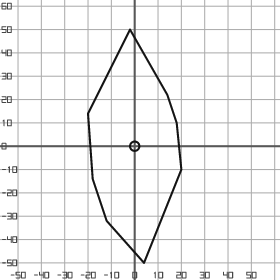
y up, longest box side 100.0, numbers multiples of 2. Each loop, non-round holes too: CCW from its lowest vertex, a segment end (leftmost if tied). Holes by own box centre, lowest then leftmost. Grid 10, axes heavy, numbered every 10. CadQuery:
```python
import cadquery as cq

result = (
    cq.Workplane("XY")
    .moveTo(4.0, -50.0)
    .lineTo(20.0, -10.0)
    .lineTo(18.0, 10.0)
    .lineTo(14.0, 22.0)
    .lineTo(-2.0, 50.0)
    .lineTo(-20.0, 14.0)
    .lineTo(-18.0, -14.0)
    .lineTo(-12.0, -32.0)
    .close()
    .moveTo(0.0, 0.0)
    .circle(2.0)
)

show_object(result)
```